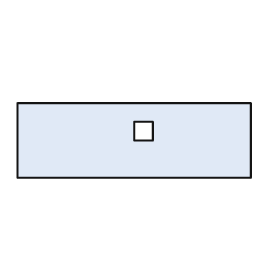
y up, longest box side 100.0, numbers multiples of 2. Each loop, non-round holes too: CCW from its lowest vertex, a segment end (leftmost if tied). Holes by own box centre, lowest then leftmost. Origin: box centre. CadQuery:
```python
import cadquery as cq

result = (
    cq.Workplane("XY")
    .moveTo(-50.0, -16.0)
    .lineTo(50.0, -16.0)
    .lineTo(50.0, 16.0)
    .lineTo(-50.0, 16.0)
    .close()
    .moveTo(0.0, 0.0)
    .lineTo(8.0, 0.0)
    .lineTo(8.0, 8.0)
    .lineTo(0.0, 8.0)
    .close()
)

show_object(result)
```